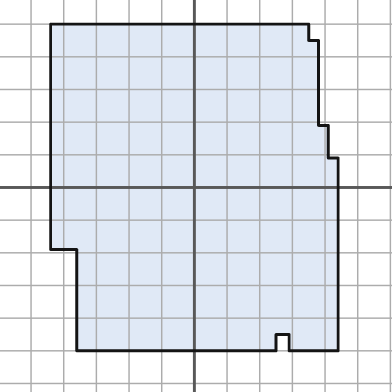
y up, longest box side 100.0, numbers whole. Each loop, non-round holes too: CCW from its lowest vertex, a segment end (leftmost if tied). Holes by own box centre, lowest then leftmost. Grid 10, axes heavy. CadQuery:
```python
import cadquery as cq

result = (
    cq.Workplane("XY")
    .moveTo(-36.0, -50.0)
    .lineTo(25.0, -50.0)
    .lineTo(25.0, -45.0)
    .lineTo(29.0, -45.0)
    .lineTo(29.0, -50.0)
    .lineTo(44.0, -50.0)
    .lineTo(44.0, 9.0)
    .lineTo(41.0, 9.0)
    .lineTo(41.0, 19.0)
    .lineTo(38.0, 19.0)
    .lineTo(38.0, 45.0)
    .lineTo(35.0, 45.0)
    .lineTo(35.0, 50.0)
    .lineTo(-44.0, 50.0)
    .lineTo(-44.0, -19.0)
    .lineTo(-36.0, -19.0)
    .close()
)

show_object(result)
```